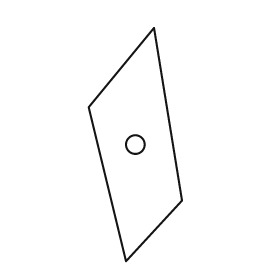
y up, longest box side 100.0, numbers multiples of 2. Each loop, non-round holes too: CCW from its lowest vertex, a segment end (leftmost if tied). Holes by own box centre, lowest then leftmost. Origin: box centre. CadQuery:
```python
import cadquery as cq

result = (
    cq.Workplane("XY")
    .moveTo(-4.0, -50.0)
    .lineTo(20.0, -24.0)
    .lineTo(8.0, 50.0)
    .lineTo(-20.0, 16.0)
    .close()
    .moveTo(0.0, 0.0)
    .circle(4.0)
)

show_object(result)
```